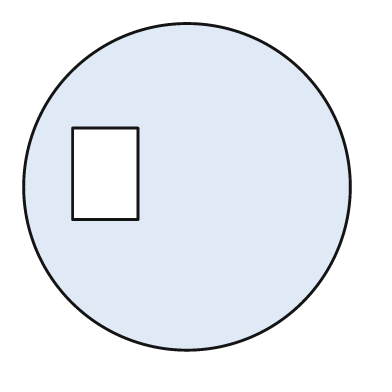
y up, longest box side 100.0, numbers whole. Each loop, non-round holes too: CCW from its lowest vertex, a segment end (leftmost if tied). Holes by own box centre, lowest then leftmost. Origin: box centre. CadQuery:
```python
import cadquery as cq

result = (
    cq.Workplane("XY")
    .moveTo(0.0, 0.0)
    .circle(50.0)
    .moveTo(-35.0, -10.0)
    .lineTo(-15.0, -10.0)
    .lineTo(-15.0, 18.0)
    .lineTo(-35.0, 18.0)
    .close()
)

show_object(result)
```